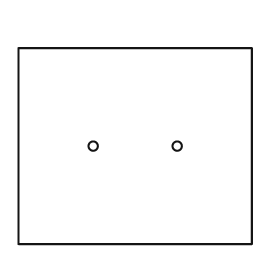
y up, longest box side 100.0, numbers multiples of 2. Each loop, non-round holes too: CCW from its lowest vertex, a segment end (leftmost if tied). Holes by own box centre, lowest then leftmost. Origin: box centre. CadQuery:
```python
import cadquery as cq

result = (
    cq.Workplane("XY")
    .moveTo(-50.0, -42.0)
    .lineTo(50.0, -42.0)
    .lineTo(50.0, 42.0)
    .lineTo(-50.0, 42.0)
    .close()
    .moveTo(-18.0, 0.0)
    .circle(2.0)
    .moveTo(18.0, 0.0)
    .circle(2.0)
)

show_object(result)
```